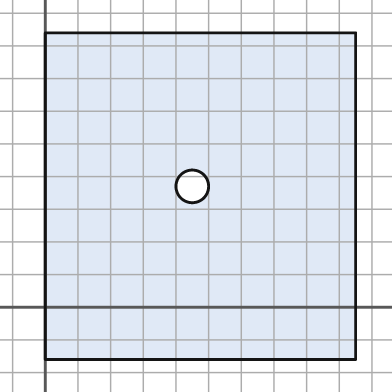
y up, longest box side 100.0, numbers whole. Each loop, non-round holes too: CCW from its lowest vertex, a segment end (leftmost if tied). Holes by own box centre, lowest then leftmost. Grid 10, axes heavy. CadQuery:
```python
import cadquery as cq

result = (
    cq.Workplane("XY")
    .moveTo(0.0, -16.0)
    .lineTo(95.0, -16.0)
    .lineTo(95.0, 84.0)
    .lineTo(0.0, 84.0)
    .close()
    .moveTo(45.0, 37.0)
    .circle(5.0)
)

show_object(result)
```